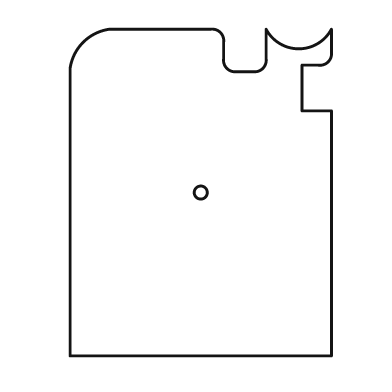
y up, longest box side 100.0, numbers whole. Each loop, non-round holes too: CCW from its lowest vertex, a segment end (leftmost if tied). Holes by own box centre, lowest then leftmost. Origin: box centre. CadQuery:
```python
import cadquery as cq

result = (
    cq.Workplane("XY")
    .moveTo(-40.0, -50.0)
    .lineTo(40.0, -50.0)
    .lineTo(40.0, 25.0)
    .lineTo(31.0, 25.0)
    .lineTo(31.0, 39.0)
    .lineTo(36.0, 39.0)
    .threePointArc((39.0, 40.0), (40.0, 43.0))
    .lineTo(40.0, 50.0)
    .threePointArc((30.0, 44.0), (20.0, 50.0))
    .lineTo(20.0, 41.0)
    .threePointArc((19.0, 38.0), (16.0, 37.0))
    .lineTo(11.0, 37.0)
    .threePointArc((8.0, 38.0), (7.0, 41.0))
    .lineTo(7.0, 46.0)
    .threePointArc((6.0, 49.0), (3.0, 50.0))
    .lineTo(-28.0, 50.0)
    .threePointArc((-36.0, 46.0), (-40.0, 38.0))
    .close()
    .moveTo(0.0, 0.0)
    .circle(2.0)
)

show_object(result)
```